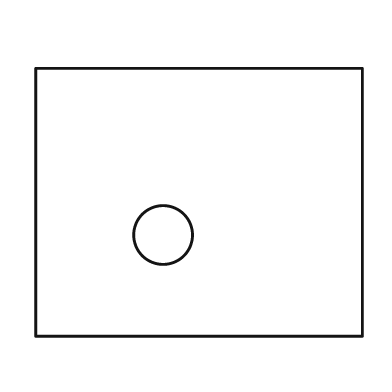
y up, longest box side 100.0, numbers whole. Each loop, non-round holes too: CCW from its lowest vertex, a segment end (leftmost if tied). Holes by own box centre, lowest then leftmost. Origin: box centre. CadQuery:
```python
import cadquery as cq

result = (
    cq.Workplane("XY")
    .moveTo(-50.0, -41.0)
    .lineTo(50.0, -41.0)
    .lineTo(50.0, 41.0)
    .lineTo(-50.0, 41.0)
    .close()
    .moveTo(-11.0, -10.0)
    .circle(9.0)
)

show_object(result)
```